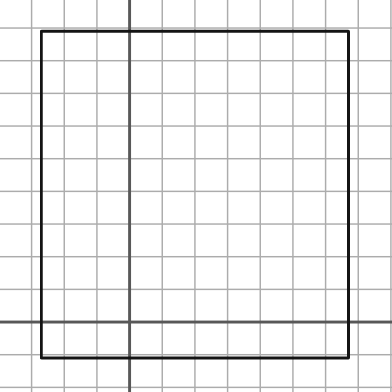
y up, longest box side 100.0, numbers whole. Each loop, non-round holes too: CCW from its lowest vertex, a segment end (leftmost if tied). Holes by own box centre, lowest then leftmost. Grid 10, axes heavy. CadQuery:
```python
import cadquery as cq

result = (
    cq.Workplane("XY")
    .moveTo(-27.0, -11.0)
    .lineTo(67.0, -11.0)
    .lineTo(67.0, 89.0)
    .lineTo(-27.0, 89.0)
    .close()
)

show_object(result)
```